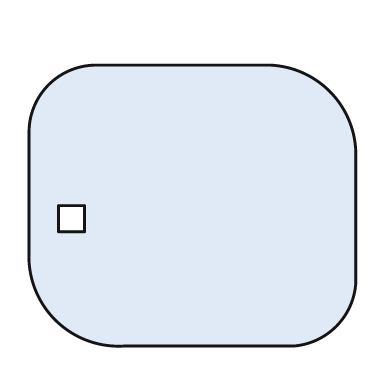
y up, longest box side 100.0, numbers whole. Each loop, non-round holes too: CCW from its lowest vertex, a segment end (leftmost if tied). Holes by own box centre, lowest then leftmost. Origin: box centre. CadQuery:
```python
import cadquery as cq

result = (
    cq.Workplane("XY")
    .moveTo(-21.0, -43.0)
    .lineTo(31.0, -43.0)
    .threePointArc((44.0, -37.0), (50.0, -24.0))
    .lineTo(50.0, 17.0)
    .threePointArc((42.0, 35.0), (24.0, 43.0))
    .lineTo(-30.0, 43.0)
    .threePointArc((-44.0, 37.0), (-50.0, 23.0))
    .lineTo(-50.0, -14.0)
    .threePointArc((-42.0, -35.0), (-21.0, -43.0))
    .close()
    .moveTo(-41.0, -8.0)
    .lineTo(-33.0, -8.0)
    .lineTo(-33.0, 0.0)
    .lineTo(-41.0, 0.0)
    .close()
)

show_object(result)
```